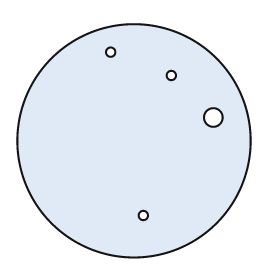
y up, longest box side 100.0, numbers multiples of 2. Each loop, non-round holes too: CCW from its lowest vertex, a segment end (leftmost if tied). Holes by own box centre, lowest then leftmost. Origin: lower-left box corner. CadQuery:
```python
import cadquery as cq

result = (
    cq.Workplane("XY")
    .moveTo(50.0, 50.0)
    .circle(50.0)
    .moveTo(54.0, 18.0)
    .circle(2.0)
    .moveTo(84.0, 60.0)
    .circle(4.0)
    .moveTo(66.0, 78.0)
    .circle(2.0)
    .moveTo(40.0, 88.0)
    .circle(2.0)
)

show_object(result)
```